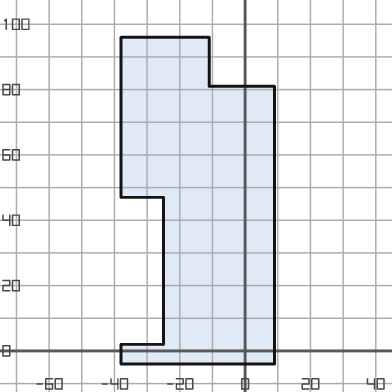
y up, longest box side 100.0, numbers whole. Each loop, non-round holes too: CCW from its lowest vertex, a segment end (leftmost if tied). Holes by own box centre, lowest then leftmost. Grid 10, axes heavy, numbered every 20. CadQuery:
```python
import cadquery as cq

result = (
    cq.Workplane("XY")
    .moveTo(-38.0, -4.0)
    .lineTo(9.0, -4.0)
    .lineTo(9.0, 81.0)
    .lineTo(-11.0, 81.0)
    .lineTo(-11.0, 96.0)
    .lineTo(-38.0, 96.0)
    .lineTo(-38.0, 47.0)
    .lineTo(-25.0, 47.0)
    .lineTo(-25.0, 2.0)
    .lineTo(-38.0, 2.0)
    .close()
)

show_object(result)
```